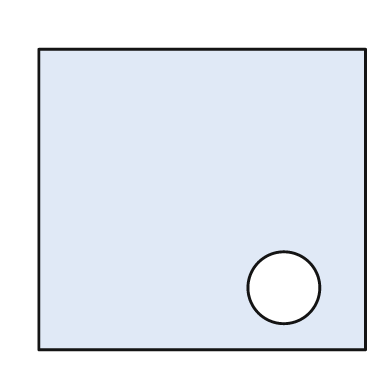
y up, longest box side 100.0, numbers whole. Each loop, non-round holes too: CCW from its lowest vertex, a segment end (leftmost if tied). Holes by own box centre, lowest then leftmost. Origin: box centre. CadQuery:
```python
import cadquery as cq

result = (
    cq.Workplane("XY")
    .moveTo(-50.0, -46.0)
    .lineTo(50.0, -46.0)
    .lineTo(50.0, 46.0)
    .lineTo(-50.0, 46.0)
    .close()
    .moveTo(25.0, -27.0)
    .circle(11.0)
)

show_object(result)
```